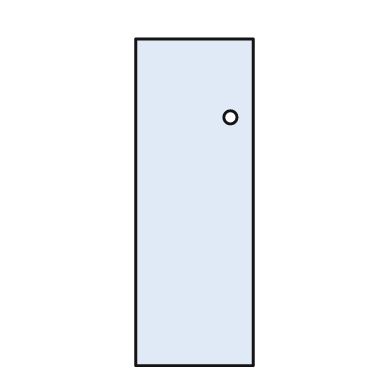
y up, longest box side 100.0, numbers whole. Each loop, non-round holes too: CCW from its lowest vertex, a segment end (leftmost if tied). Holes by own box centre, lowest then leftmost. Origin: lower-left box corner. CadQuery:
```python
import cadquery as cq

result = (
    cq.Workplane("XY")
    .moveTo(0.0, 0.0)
    .lineTo(36.0, 0.0)
    .lineTo(36.0, 100.0)
    .lineTo(0.0, 100.0)
    .close()
    .moveTo(29.0, 76.0)
    .circle(2.0)
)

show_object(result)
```